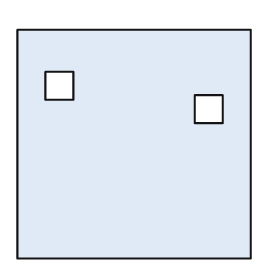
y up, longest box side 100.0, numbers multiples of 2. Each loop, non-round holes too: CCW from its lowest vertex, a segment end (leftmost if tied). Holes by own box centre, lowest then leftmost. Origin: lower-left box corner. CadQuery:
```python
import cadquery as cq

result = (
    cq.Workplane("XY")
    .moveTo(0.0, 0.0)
    .lineTo(100.0, 0.0)
    .lineTo(100.0, 98.0)
    .lineTo(0.0, 98.0)
    .close()
    .moveTo(76.0, 58.0)
    .lineTo(88.0, 58.0)
    .lineTo(88.0, 70.0)
    .lineTo(76.0, 70.0)
    .close()
    .moveTo(12.0, 68.0)
    .lineTo(24.0, 68.0)
    .lineTo(24.0, 80.0)
    .lineTo(12.0, 80.0)
    .close()
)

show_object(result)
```